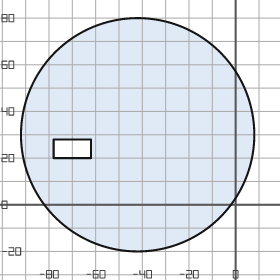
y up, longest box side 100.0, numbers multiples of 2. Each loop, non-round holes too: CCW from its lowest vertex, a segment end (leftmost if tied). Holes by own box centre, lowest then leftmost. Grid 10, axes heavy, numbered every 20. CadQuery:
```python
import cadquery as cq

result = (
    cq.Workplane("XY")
    .moveTo(-42.0, 30.0)
    .circle(50.0)
    .moveTo(-78.0, 20.0)
    .lineTo(-62.0, 20.0)
    .lineTo(-62.0, 28.0)
    .lineTo(-78.0, 28.0)
    .close()
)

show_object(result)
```